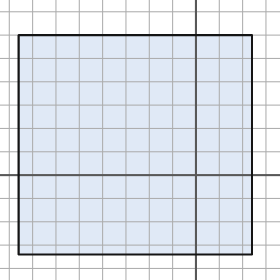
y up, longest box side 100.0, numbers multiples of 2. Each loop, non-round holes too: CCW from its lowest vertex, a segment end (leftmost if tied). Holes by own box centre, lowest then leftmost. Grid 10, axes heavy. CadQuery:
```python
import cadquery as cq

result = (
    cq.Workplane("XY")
    .moveTo(-76.0, -34.0)
    .lineTo(24.0, -34.0)
    .lineTo(24.0, 60.0)
    .lineTo(-76.0, 60.0)
    .close()
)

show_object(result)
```